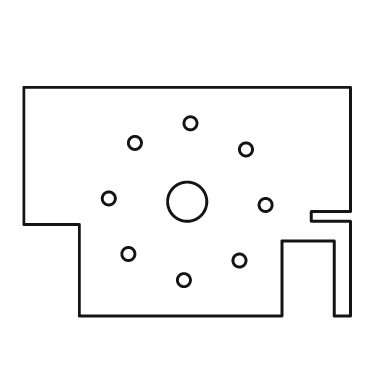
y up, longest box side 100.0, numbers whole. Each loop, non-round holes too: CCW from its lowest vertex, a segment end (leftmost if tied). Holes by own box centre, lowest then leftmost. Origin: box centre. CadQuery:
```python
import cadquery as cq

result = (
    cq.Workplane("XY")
    .moveTo(-33.0, -35.0)
    .lineTo(29.0, -35.0)
    .lineTo(29.0, -12.0)
    .lineTo(45.0, -12.0)
    .lineTo(45.0, -35.0)
    .lineTo(50.0, -35.0)
    .lineTo(50.0, -6.0)
    .lineTo(38.0, -6.0)
    .lineTo(38.0, -3.0)
    .lineTo(50.0, -3.0)
    .lineTo(50.0, 35.0)
    .lineTo(-50.0, 35.0)
    .lineTo(-50.0, -7.0)
    .lineTo(-33.0, -7.0)
    .close()
    .moveTo(-1.0, -24.0)
    .circle(2.0)
    .moveTo(16.0, -18.0)
    .circle(2.0)
    .moveTo(-18.0, -16.0)
    .circle(2.0)
    .moveTo(24.0, -1.0)
    .circle(2.0)
    .moveTo(0.0, 0.0)
    .circle(6.0)
    .moveTo(-24.0, 1.0)
    .circle(2.0)
    .moveTo(18.0, 16.0)
    .circle(2.0)
    .moveTo(-16.0, 18.0)
    .circle(2.0)
    .moveTo(1.0, 24.0)
    .circle(2.0)
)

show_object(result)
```